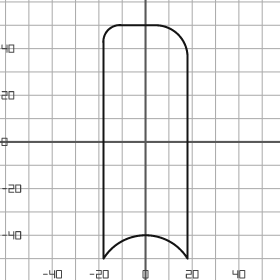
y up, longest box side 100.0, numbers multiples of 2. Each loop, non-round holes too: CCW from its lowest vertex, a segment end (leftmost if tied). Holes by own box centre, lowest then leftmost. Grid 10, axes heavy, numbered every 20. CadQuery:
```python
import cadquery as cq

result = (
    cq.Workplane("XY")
    .moveTo(-18.0, -50.0)
    .threePointArc((0.0, -40.0), (18.0, -50.0))
    .lineTo(18.0, 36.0)
    .threePointArc((14.0, 46.0), (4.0, 50.0))
    .lineTo(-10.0, 50.0)
    .threePointArc((-16.0, 48.0), (-18.0, 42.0))
    .close()
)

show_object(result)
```